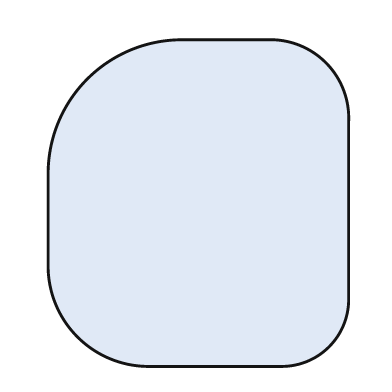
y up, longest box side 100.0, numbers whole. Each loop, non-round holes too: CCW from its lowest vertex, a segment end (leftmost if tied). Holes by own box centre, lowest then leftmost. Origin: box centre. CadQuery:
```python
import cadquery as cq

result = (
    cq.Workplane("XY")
    .moveTo(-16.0, -50.0)
    .lineTo(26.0, -50.0)
    .threePointArc((40.0, -44.0), (46.0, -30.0))
    .lineTo(46.0, 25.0)
    .threePointArc((39.0, 43.0), (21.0, 50.0))
    .lineTo(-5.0, 50.0)
    .threePointArc((-34.0, 38.0), (-46.0, 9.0))
    .lineTo(-46.0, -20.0)
    .threePointArc((-37.0, -41.0), (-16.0, -50.0))
    .close()
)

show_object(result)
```